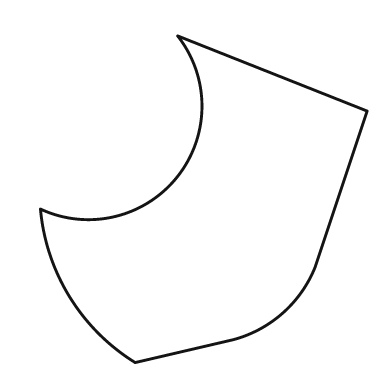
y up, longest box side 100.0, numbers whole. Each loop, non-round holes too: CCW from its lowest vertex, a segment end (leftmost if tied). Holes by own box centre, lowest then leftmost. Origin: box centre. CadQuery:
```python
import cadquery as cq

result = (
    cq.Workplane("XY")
    .moveTo(-21.0, -50.0)
    .lineTo(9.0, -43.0)
    .threePointArc((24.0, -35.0), (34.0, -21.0))
    .lineTo(50.0, 27.0)
    .lineTo(-8.0, 50.0)
    .threePointArc((-8.0, 7.0), (-50.0, -3.0))
    .threePointArc((-41.0, -30.0), (-21.0, -50.0))
    .close()
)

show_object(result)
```